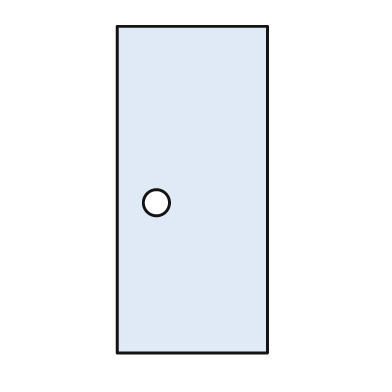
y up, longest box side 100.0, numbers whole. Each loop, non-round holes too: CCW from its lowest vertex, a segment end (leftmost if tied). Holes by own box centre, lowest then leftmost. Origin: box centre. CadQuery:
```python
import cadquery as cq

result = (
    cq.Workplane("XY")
    .moveTo(-23.0, -50.0)
    .lineTo(23.0, -50.0)
    .lineTo(23.0, 50.0)
    .lineTo(-23.0, 50.0)
    .close()
    .moveTo(-11.0, -4.0)
    .circle(4.0)
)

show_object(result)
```